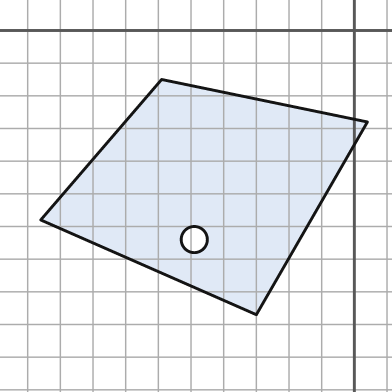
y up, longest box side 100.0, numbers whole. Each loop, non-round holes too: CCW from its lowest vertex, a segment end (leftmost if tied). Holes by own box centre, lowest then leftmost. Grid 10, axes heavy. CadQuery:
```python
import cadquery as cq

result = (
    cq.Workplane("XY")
    .moveTo(-30.0, -87.0)
    .lineTo(4.0, -28.0)
    .lineTo(-59.0, -15.0)
    .lineTo(-96.0, -58.0)
    .close()
    .moveTo(-49.0, -64.0)
    .circle(4.0)
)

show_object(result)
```